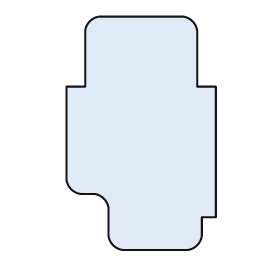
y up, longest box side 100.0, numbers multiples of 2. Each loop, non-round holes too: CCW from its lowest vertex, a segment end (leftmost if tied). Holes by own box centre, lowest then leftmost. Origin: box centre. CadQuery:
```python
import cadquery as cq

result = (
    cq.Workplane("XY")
    .moveTo(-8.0, -50.0)
    .lineTo(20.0, -50.0)
    .threePointArc((24.0, -48.0), (26.0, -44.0))
    .lineTo(26.0, -36.0)
    .lineTo(32.0, -36.0)
    .lineTo(32.0, 20.0)
    .lineTo(24.0, 20.0)
    .lineTo(24.0, 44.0)
    .threePointArc((22.0, 48.0), (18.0, 50.0))
    .lineTo(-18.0, 50.0)
    .threePointArc((-22.0, 48.0), (-24.0, 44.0))
    .lineTo(-24.0, 20.0)
    .lineTo(-32.0, 20.0)
    .lineTo(-32.0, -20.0)
    .threePointArc((-30.0, -24.0), (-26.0, -26.0))
    .lineTo(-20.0, -26.0)
    .threePointArc((-16.0, -28.0), (-14.0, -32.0))
    .lineTo(-14.0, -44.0)
    .threePointArc((-12.0, -48.0), (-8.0, -50.0))
    .close()
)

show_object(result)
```